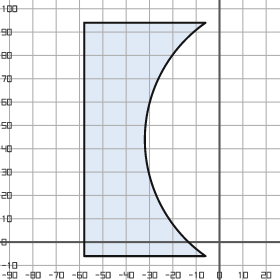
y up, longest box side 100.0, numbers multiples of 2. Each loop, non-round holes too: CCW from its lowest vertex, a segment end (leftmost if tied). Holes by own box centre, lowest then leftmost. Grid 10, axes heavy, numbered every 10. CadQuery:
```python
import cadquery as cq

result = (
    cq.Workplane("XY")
    .moveTo(-58.0, -6.0)
    .lineTo(-6.0, -6.0)
    .threePointArc((-32.0, 44.0), (-6.0, 94.0))
    .lineTo(-58.0, 94.0)
    .close()
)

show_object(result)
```